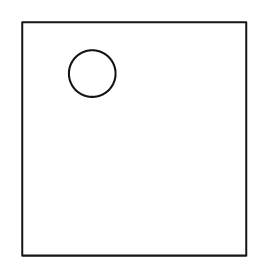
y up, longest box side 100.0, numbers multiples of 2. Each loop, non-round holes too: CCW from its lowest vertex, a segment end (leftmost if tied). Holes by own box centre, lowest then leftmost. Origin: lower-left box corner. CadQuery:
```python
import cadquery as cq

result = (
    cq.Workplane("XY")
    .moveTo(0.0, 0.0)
    .lineTo(96.0, 0.0)
    .lineTo(96.0, 100.0)
    .lineTo(0.0, 100.0)
    .close()
    .moveTo(30.0, 78.0)
    .circle(10.0)
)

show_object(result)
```